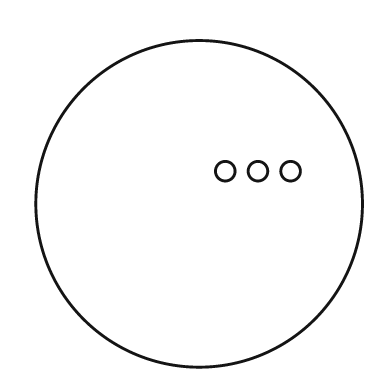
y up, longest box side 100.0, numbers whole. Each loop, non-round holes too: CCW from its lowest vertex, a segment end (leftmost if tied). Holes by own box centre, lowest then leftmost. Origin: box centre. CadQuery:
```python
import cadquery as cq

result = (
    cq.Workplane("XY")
    .moveTo(0.0, 0.0)
    .circle(50.0)
    .moveTo(8.0, 10.0)
    .circle(3.0)
    .moveTo(18.0, 10.0)
    .circle(3.0)
    .moveTo(28.0, 10.0)
    .circle(3.0)
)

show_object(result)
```